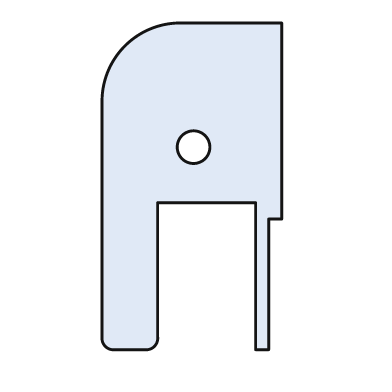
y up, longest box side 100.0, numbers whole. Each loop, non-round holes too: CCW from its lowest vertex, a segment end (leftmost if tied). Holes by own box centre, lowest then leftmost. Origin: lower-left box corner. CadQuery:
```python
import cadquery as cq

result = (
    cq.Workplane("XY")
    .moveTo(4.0, 0.0)
    .lineTo(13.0, 0.0)
    .threePointArc((16.0, 1.0), (17.0, 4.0))
    .lineTo(17.0, 45.0)
    .lineTo(47.0, 45.0)
    .lineTo(47.0, 0.0)
    .lineTo(51.0, 0.0)
    .lineTo(51.0, 40.0)
    .lineTo(55.0, 40.0)
    .lineTo(55.0, 100.0)
    .lineTo(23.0, 100.0)
    .threePointArc((7.0, 93.0), (0.0, 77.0))
    .lineTo(0.0, 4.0)
    .threePointArc((1.0, 1.0), (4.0, 0.0))
    .close()
    .moveTo(28.0, 62.0)
    .circle(5.0)
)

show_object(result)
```